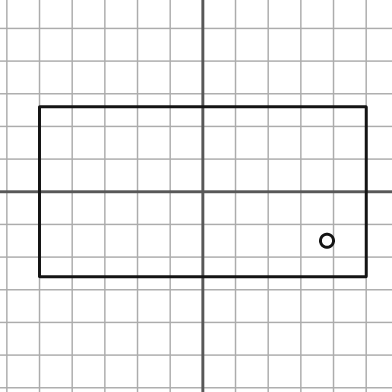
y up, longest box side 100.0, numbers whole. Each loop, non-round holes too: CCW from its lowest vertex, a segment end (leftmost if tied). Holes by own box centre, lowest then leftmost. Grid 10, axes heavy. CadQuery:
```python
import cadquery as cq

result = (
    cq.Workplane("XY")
    .moveTo(-50.0, -26.0)
    .lineTo(50.0, -26.0)
    .lineTo(50.0, 26.0)
    .lineTo(-50.0, 26.0)
    .close()
    .moveTo(38.0, -15.0)
    .circle(2.0)
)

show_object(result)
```